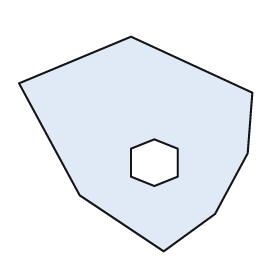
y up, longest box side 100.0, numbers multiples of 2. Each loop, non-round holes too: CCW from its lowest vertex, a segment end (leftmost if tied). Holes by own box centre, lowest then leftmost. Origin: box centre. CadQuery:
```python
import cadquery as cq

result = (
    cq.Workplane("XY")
    .moveTo(12.0, -46.0)
    .lineTo(34.0, -30.0)
    .lineTo(48.0, -4.0)
    .lineTo(50.0, 22.0)
    .lineTo(-2.0, 46.0)
    .lineTo(-50.0, 26.0)
    .lineTo(-24.0, -22.0)
    .close()
    .moveTo(8.0, -18.0)
    .lineTo(18.0, -14.0)
    .lineTo(18.0, -2.0)
    .lineTo(8.0, 2.0)
    .lineTo(-2.0, -2.0)
    .lineTo(-2.0, -14.0)
    .close()
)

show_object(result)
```